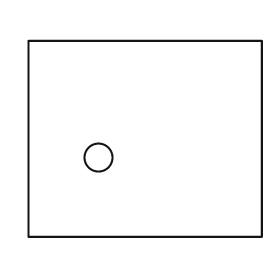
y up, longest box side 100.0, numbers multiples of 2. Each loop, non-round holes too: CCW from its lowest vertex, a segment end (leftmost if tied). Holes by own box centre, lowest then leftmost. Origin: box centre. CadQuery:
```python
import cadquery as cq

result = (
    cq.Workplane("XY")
    .moveTo(-50.0, -42.0)
    .lineTo(50.0, -42.0)
    .lineTo(50.0, 42.0)
    .lineTo(-50.0, 42.0)
    .close()
    .moveTo(-20.0, -8.0)
    .circle(6.0)
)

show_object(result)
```